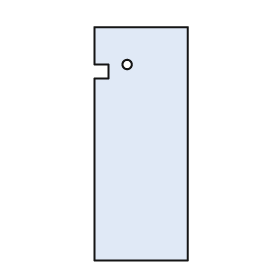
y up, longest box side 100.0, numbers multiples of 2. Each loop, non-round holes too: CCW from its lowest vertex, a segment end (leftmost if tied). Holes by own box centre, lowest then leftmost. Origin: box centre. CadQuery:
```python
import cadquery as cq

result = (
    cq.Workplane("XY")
    .moveTo(-20.0, -50.0)
    .lineTo(20.0, -50.0)
    .lineTo(20.0, 50.0)
    .lineTo(-20.0, 50.0)
    .lineTo(-20.0, 34.0)
    .lineTo(-14.0, 34.0)
    .lineTo(-14.0, 28.0)
    .lineTo(-20.0, 28.0)
    .close()
    .moveTo(-6.0, 34.0)
    .circle(2.0)
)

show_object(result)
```